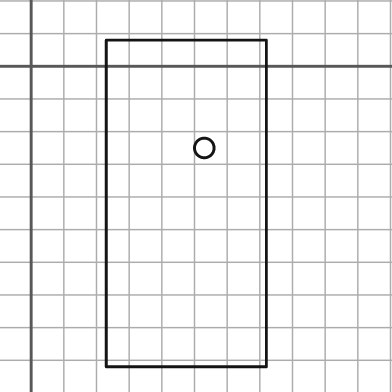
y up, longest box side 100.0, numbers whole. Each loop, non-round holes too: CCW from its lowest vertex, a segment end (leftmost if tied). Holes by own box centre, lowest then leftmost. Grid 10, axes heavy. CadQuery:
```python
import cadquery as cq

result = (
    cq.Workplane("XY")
    .moveTo(23.0, -92.0)
    .lineTo(72.0, -92.0)
    .lineTo(72.0, 8.0)
    .lineTo(23.0, 8.0)
    .close()
    .moveTo(53.0, -25.0)
    .circle(3.0)
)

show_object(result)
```